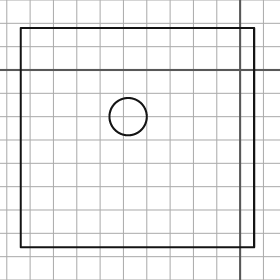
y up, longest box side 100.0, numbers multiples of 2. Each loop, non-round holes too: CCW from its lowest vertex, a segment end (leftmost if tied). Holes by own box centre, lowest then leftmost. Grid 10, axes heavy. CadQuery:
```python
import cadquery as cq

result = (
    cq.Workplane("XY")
    .moveTo(-94.0, -76.0)
    .lineTo(6.0, -76.0)
    .lineTo(6.0, 18.0)
    .lineTo(-94.0, 18.0)
    .close()
    .moveTo(-48.0, -20.0)
    .circle(8.0)
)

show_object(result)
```